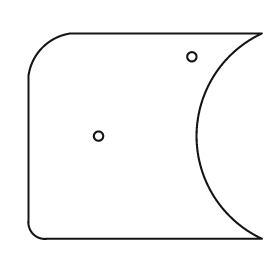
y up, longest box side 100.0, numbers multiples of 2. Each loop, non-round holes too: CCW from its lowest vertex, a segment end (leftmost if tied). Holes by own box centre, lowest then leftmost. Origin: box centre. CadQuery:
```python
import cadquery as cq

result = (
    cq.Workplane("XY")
    .moveTo(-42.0, -44.0)
    .lineTo(50.0, -44.0)
    .threePointArc((22.0, 0.0), (50.0, 44.0))
    .lineTo(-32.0, 44.0)
    .threePointArc((-44.0, 38.0), (-50.0, 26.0))
    .lineTo(-50.0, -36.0)
    .threePointArc((-48.0, -42.0), (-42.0, -44.0))
    .close()
    .moveTo(-20.0, 0.0)
    .circle(2.0)
    .moveTo(20.0, 34.0)
    .circle(2.0)
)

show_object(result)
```